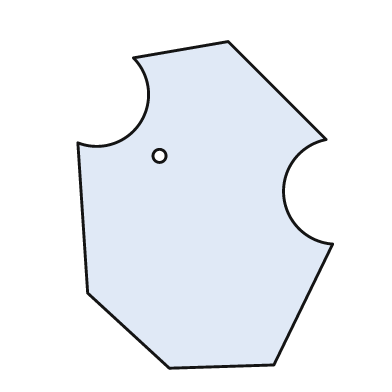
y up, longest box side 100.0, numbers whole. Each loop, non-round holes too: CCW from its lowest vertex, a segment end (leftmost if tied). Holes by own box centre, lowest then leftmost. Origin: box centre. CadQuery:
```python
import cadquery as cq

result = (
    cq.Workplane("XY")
    .moveTo(-11.0, -50.0)
    .lineTo(21.0, -49.0)
    .lineTo(39.0, -12.0)
    .threePointArc((24.0, 3.0), (37.0, 20.0))
    .lineTo(7.0, 50.0)
    .lineTo(-22.0, 45.0)
    .threePointArc((-20.0, 25.0), (-39.0, 19.0))
    .lineTo(-36.0, -27.0)
    .close()
    .moveTo(-14.0, 15.0)
    .circle(2.0)
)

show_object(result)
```